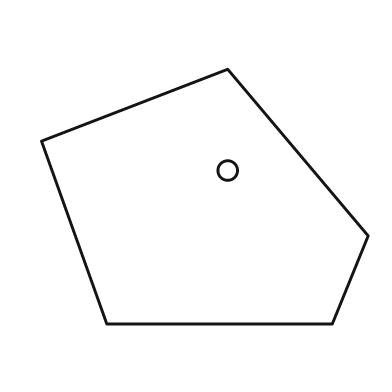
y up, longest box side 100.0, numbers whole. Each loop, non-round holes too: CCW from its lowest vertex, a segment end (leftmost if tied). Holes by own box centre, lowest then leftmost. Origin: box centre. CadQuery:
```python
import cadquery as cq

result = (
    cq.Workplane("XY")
    .moveTo(-30.0, -39.0)
    .lineTo(39.0, -39.0)
    .lineTo(50.0, -12.0)
    .lineTo(7.0, 39.0)
    .lineTo(-50.0, 17.0)
    .close()
    .moveTo(7.0, 8.0)
    .circle(3.0)
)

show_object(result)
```